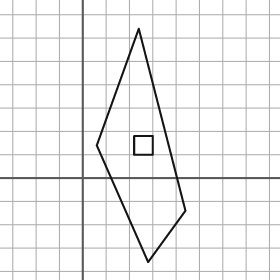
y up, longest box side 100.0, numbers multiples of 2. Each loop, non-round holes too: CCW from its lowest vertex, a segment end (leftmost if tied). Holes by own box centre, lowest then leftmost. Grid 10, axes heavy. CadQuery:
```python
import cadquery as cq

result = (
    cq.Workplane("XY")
    .moveTo(28.0, -36.0)
    .lineTo(44.0, -14.0)
    .lineTo(24.0, 64.0)
    .lineTo(6.0, 14.0)
    .close()
    .moveTo(22.0, 10.0)
    .lineTo(30.0, 10.0)
    .lineTo(30.0, 18.0)
    .lineTo(22.0, 18.0)
    .close()
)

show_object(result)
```